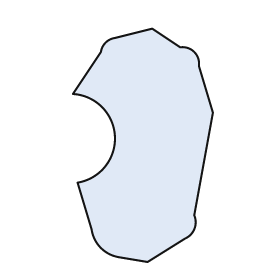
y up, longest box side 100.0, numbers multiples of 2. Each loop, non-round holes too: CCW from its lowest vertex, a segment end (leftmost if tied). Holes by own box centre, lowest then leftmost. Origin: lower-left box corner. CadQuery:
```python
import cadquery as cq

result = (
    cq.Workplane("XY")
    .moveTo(32.0, 0.0)
    .lineTo(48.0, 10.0)
    .threePointArc((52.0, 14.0), (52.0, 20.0))
    .lineTo(60.0, 64.0)
    .lineTo(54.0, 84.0)
    .threePointArc((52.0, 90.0), (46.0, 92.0))
    .lineTo(34.0, 100.0)
    .lineTo(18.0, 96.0)
    .threePointArc((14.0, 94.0), (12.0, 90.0))
    .lineTo(0.0, 72.0)
    .threePointArc((18.0, 54.0), (2.0, 34.0))
    .lineTo(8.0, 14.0)
    .threePointArc((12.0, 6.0), (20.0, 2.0))
    .close()
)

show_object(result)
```